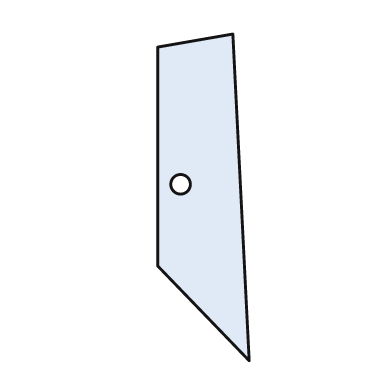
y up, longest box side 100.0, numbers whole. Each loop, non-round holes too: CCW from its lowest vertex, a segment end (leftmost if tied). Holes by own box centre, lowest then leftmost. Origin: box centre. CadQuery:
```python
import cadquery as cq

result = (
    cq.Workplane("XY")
    .moveTo(14.0, -50.0)
    .lineTo(9.0, 50.0)
    .lineTo(-14.0, 46.0)
    .lineTo(-14.0, -21.0)
    .close()
    .moveTo(-7.0, 4.0)
    .circle(3.0)
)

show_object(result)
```